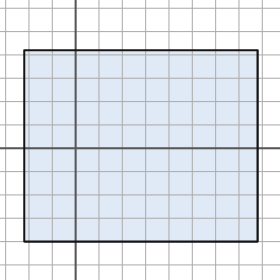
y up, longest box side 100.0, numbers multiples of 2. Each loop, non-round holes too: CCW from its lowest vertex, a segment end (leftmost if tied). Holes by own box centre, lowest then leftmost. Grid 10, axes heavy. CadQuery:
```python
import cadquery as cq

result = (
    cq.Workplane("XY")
    .moveTo(-22.0, -40.0)
    .lineTo(78.0, -40.0)
    .lineTo(78.0, 42.0)
    .lineTo(-22.0, 42.0)
    .close()
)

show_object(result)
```